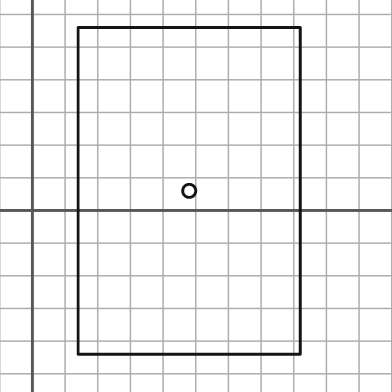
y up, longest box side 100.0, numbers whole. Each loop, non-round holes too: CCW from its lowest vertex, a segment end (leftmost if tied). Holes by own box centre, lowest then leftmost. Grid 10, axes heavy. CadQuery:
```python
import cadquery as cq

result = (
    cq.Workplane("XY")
    .moveTo(14.0, -44.0)
    .lineTo(82.0, -44.0)
    .lineTo(82.0, 56.0)
    .lineTo(14.0, 56.0)
    .close()
    .moveTo(48.0, 6.0)
    .circle(2.0)
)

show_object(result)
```